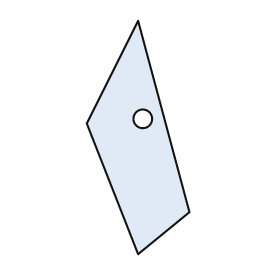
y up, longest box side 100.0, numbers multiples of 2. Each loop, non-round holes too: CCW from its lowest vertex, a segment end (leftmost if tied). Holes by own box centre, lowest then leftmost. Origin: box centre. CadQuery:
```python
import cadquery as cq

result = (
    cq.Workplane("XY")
    .moveTo(0.0, -50.0)
    .lineTo(22.0, -32.0)
    .lineTo(0.0, 50.0)
    .lineTo(-22.0, 6.0)
    .close()
    .moveTo(2.0, 8.0)
    .circle(4.0)
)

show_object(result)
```